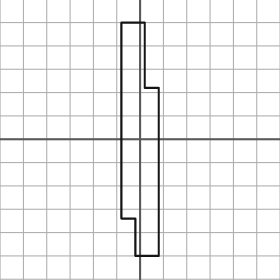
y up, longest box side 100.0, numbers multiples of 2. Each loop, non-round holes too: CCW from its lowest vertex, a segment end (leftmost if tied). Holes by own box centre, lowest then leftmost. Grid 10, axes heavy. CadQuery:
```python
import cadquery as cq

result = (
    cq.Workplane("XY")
    .moveTo(-2.0, -50.0)
    .lineTo(8.0, -50.0)
    .lineTo(8.0, 22.0)
    .lineTo(2.0, 22.0)
    .lineTo(2.0, 50.0)
    .lineTo(-8.0, 50.0)
    .lineTo(-8.0, -34.0)
    .lineTo(-2.0, -34.0)
    .close()
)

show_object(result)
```